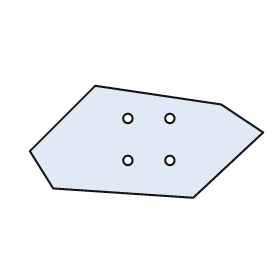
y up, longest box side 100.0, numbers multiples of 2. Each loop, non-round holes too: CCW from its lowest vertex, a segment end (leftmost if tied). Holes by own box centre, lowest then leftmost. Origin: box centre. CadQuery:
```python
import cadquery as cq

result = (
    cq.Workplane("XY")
    .moveTo(20.0, -24.0)
    .lineTo(50.0, 4.0)
    .lineTo(32.0, 16.0)
    .lineTo(-22.0, 24.0)
    .lineTo(-50.0, -4.0)
    .lineTo(-40.0, -20.0)
    .close()
    .moveTo(-8.0, -8.0)
    .circle(2.0)
    .moveTo(10.0, -8.0)
    .circle(2.0)
    .moveTo(-8.0, 10.0)
    .circle(2.0)
    .moveTo(10.0, 10.0)
    .circle(2.0)
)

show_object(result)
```